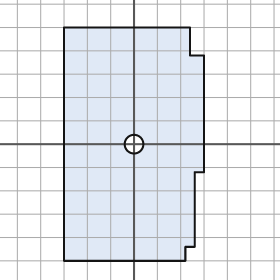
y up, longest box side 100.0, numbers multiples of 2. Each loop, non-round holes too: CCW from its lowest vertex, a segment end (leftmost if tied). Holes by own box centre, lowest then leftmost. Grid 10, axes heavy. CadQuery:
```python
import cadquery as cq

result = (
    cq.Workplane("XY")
    .moveTo(-30.0, -50.0)
    .lineTo(22.0, -50.0)
    .lineTo(22.0, -44.0)
    .lineTo(26.0, -44.0)
    .lineTo(26.0, -12.0)
    .lineTo(30.0, -12.0)
    .lineTo(30.0, 38.0)
    .lineTo(24.0, 38.0)
    .lineTo(24.0, 50.0)
    .lineTo(-30.0, 50.0)
    .close()
    .moveTo(0.0, 0.0)
    .circle(4.0)
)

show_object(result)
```